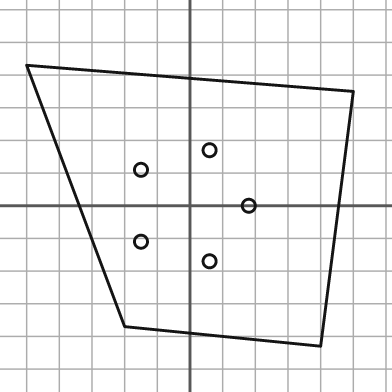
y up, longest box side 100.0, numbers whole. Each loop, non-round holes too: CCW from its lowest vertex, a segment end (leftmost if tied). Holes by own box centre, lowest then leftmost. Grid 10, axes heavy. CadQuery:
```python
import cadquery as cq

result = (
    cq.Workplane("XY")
    .moveTo(40.0, -43.0)
    .lineTo(50.0, 35.0)
    .lineTo(-50.0, 43.0)
    .lineTo(-20.0, -37.0)
    .close()
    .moveTo(6.0, -17.0)
    .circle(2.0)
    .moveTo(-15.0, -11.0)
    .circle(2.0)
    .moveTo(18.0, 0.0)
    .circle(2.0)
    .moveTo(-15.0, 11.0)
    .circle(2.0)
    .moveTo(6.0, 17.0)
    .circle(2.0)
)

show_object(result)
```